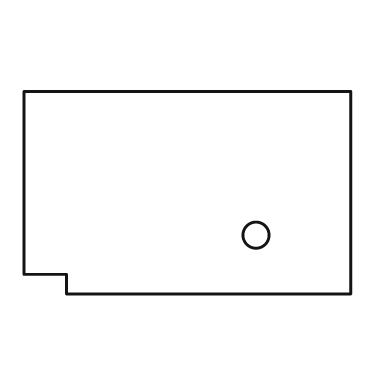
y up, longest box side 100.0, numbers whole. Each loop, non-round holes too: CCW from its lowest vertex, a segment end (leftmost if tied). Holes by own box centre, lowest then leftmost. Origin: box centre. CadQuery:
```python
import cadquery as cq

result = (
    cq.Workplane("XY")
    .moveTo(-37.0, -31.0)
    .lineTo(50.0, -31.0)
    .lineTo(50.0, 31.0)
    .lineTo(-50.0, 31.0)
    .lineTo(-50.0, -25.0)
    .lineTo(-37.0, -25.0)
    .close()
    .moveTo(21.0, -13.0)
    .circle(4.0)
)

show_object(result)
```